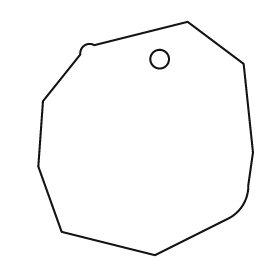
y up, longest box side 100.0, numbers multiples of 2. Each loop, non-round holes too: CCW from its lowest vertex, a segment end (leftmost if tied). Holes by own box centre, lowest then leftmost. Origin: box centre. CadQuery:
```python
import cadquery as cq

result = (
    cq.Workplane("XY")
    .moveTo(4.0, -50.0)
    .lineTo(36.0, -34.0)
    .threePointArc((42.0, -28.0), (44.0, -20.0))
    .lineTo(46.0, -6.0)
    .lineTo(42.0, 32.0)
    .lineTo(18.0, 50.0)
    .lineTo(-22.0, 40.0)
    .threePointArc((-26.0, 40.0), (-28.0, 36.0))
    .lineTo(-44.0, 16.0)
    .lineTo(-46.0, -12.0)
    .lineTo(-36.0, -40.0)
    .close()
    .moveTo(6.0, 34.0)
    .circle(4.0)
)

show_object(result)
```